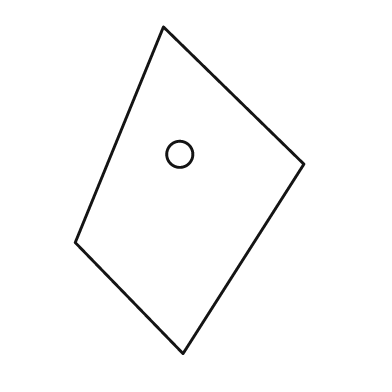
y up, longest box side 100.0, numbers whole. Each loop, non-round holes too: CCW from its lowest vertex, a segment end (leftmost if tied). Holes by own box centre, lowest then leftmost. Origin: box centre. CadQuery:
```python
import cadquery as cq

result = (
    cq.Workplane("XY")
    .moveTo(-2.0, -50.0)
    .lineTo(35.0, 8.0)
    .lineTo(-8.0, 50.0)
    .lineTo(-35.0, -16.0)
    .close()
    .moveTo(-3.0, 11.0)
    .circle(4.0)
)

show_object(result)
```